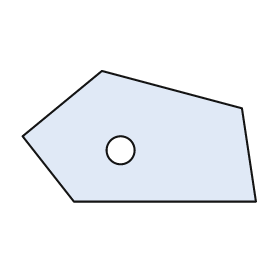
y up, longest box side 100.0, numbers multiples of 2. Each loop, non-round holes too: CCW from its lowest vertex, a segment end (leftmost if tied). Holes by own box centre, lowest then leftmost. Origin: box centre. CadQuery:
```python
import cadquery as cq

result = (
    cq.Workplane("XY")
    .moveTo(-28.0, -28.0)
    .lineTo(50.0, -28.0)
    .lineTo(44.0, 12.0)
    .lineTo(-16.0, 28.0)
    .lineTo(-50.0, 0.0)
    .close()
    .moveTo(-8.0, -6.0)
    .circle(6.0)
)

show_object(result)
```